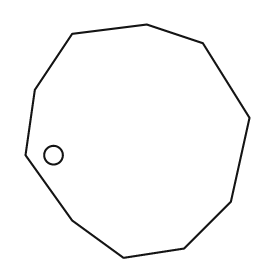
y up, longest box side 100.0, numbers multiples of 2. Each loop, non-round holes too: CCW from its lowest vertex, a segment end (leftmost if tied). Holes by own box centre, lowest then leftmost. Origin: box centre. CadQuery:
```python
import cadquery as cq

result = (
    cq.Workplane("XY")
    .moveTo(-6.0, -50.0)
    .lineTo(20.0, -46.0)
    .lineTo(40.0, -26.0)
    .lineTo(48.0, 10.0)
    .lineTo(28.0, 42.0)
    .lineTo(4.0, 50.0)
    .lineTo(-28.0, 46.0)
    .lineTo(-44.0, 22.0)
    .lineTo(-48.0, -6.0)
    .lineTo(-28.0, -34.0)
    .close()
    .moveTo(-36.0, -6.0)
    .circle(4.0)
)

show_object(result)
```